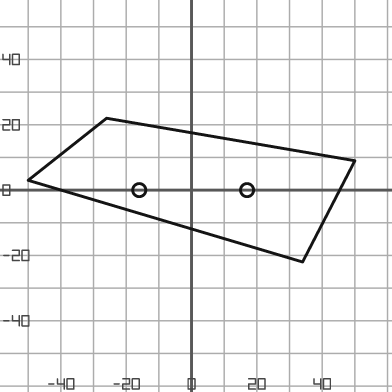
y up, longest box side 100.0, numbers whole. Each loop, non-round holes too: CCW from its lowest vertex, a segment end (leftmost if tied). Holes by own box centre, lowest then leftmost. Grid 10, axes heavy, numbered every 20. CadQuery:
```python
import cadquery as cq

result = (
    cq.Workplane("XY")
    .moveTo(34.0, -22.0)
    .lineTo(50.0, 9.0)
    .lineTo(-26.0, 22.0)
    .lineTo(-50.0, 3.0)
    .close()
    .moveTo(-16.0, 0.0)
    .circle(2.0)
    .moveTo(17.0, 0.0)
    .circle(2.0)
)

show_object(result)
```